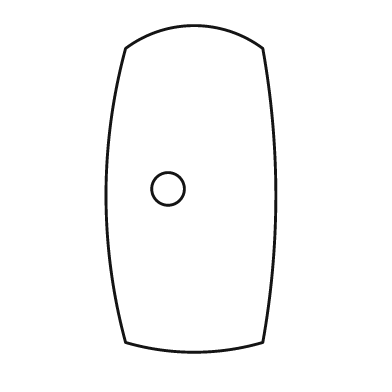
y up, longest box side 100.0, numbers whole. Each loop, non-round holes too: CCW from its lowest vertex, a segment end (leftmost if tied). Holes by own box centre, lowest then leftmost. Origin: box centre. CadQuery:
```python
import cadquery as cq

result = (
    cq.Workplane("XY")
    .moveTo(-20.0, -47.0)
    .threePointArc((1.0, -50.0), (22.0, -47.0))
    .threePointArc((26.0, -2.0), (22.0, 43.0))
    .threePointArc((1.0, 50.0), (-20.0, 43.0))
    .threePointArc((-26.0, -2.0), (-20.0, -47.0))
    .close()
    .moveTo(-7.0, 0.0)
    .circle(5.0)
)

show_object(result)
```